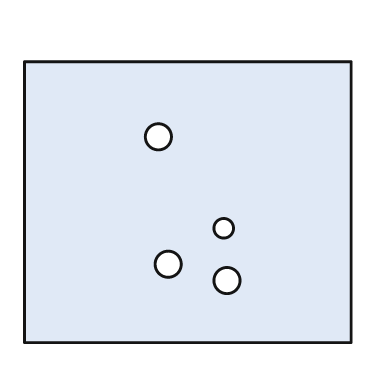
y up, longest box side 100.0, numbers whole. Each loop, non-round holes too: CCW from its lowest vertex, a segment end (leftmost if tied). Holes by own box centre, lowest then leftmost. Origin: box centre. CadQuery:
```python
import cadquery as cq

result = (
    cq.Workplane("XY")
    .moveTo(-50.0, -43.0)
    .lineTo(50.0, -43.0)
    .lineTo(50.0, 43.0)
    .lineTo(-50.0, 43.0)
    .close()
    .moveTo(12.0, -24.0)
    .circle(4.0)
    .moveTo(-6.0, -19.0)
    .circle(4.0)
    .moveTo(11.0, -8.0)
    .circle(3.0)
    .moveTo(-9.0, 20.0)
    .circle(4.0)
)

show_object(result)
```